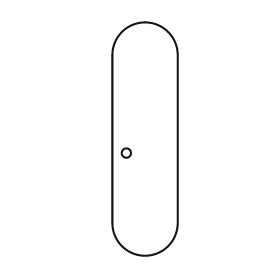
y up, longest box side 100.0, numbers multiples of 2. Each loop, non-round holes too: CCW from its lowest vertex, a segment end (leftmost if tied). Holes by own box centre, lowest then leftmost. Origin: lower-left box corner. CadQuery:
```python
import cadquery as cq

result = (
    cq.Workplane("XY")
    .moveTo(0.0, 14.0)
    .threePointArc((14.0, 0.0), (28.0, 14.0))
    .lineTo(28.0, 86.0)
    .threePointArc((14.0, 100.0), (0.0, 86.0))
    .close()
    .moveTo(6.0, 44.0)
    .circle(2.0)
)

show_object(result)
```